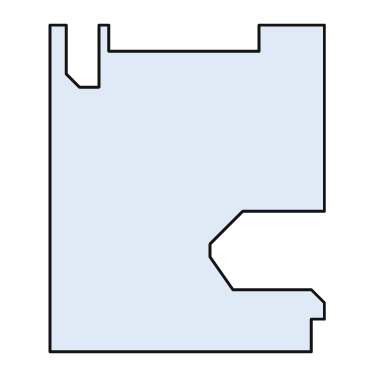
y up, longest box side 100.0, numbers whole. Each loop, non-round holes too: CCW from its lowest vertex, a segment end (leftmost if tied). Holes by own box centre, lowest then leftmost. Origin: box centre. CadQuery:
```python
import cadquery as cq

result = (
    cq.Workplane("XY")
    .moveTo(-42.0, -50.0)
    .lineTo(38.0, -50.0)
    .lineTo(38.0, -40.0)
    .lineTo(42.0, -40.0)
    .lineTo(42.0, -35.0)
    .lineTo(38.0, -31.0)
    .lineTo(14.0, -31.0)
    .lineTo(7.0, -21.0)
    .lineTo(7.0, -17.0)
    .lineTo(17.0, -7.0)
    .lineTo(42.0, -7.0)
    .lineTo(42.0, 50.0)
    .lineTo(22.0, 50.0)
    .lineTo(22.0, 42.0)
    .lineTo(-24.0, 42.0)
    .lineTo(-24.0, 50.0)
    .lineTo(-27.0, 50.0)
    .lineTo(-27.0, 31.0)
    .lineTo(-33.0, 31.0)
    .lineTo(-37.0, 35.0)
    .lineTo(-37.0, 50.0)
    .lineTo(-42.0, 50.0)
    .close()
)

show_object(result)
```